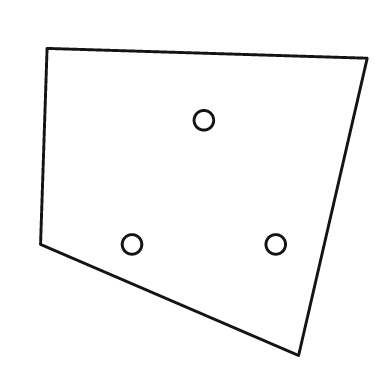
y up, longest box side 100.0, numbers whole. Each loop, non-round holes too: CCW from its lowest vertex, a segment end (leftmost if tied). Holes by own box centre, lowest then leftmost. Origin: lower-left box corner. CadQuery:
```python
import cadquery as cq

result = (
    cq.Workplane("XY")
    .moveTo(79.0, 0.0)
    .lineTo(100.0, 91.0)
    .lineTo(2.0, 94.0)
    .lineTo(0.0, 34.0)
    .close()
    .moveTo(28.0, 34.0)
    .circle(3.0)
    .moveTo(72.0, 34.0)
    .circle(3.0)
    .moveTo(50.0, 72.0)
    .circle(3.0)
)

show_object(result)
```